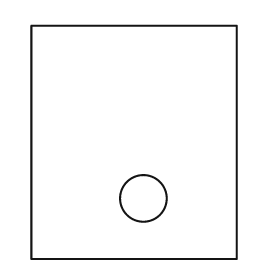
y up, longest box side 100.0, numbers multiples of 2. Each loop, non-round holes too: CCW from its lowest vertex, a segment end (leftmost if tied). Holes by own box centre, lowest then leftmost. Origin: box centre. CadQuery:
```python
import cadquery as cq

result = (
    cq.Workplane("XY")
    .moveTo(-44.0, -50.0)
    .lineTo(44.0, -50.0)
    .lineTo(44.0, 50.0)
    .lineTo(-44.0, 50.0)
    .close()
    .moveTo(4.0, -24.0)
    .circle(10.0)
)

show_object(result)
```